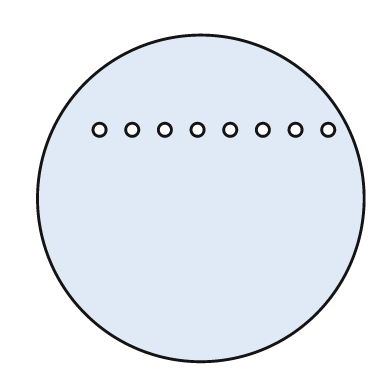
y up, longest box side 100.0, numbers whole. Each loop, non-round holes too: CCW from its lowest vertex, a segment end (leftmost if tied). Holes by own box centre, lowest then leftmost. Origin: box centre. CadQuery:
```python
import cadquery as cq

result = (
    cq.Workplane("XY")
    .moveTo(0.0, 0.0)
    .circle(50.0)
    .moveTo(-31.0, 21.0)
    .circle(2.0)
    .moveTo(-21.0, 21.0)
    .circle(2.0)
    .moveTo(-11.0, 21.0)
    .circle(2.0)
    .moveTo(-1.0, 21.0)
    .circle(2.0)
    .moveTo(9.0, 21.0)
    .circle(2.0)
    .moveTo(19.0, 21.0)
    .circle(2.0)
    .moveTo(29.0, 21.0)
    .circle(2.0)
    .moveTo(39.0, 21.0)
    .circle(2.0)
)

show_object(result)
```